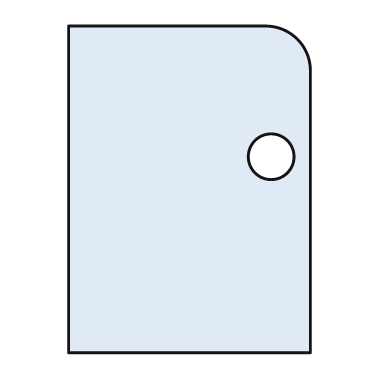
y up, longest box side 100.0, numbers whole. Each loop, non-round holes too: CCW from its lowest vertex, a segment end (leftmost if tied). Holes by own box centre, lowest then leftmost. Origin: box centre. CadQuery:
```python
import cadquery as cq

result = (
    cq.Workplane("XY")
    .moveTo(-37.0, -50.0)
    .lineTo(37.0, -50.0)
    .lineTo(37.0, 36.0)
    .threePointArc((33.0, 46.0), (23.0, 50.0))
    .lineTo(-37.0, 50.0)
    .close()
    .moveTo(25.0, 10.0)
    .circle(7.0)
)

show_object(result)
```